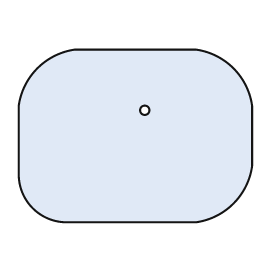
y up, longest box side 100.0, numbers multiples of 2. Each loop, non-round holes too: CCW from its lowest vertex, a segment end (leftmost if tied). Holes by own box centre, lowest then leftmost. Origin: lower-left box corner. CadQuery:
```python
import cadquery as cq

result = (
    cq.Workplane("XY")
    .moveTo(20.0, 0.0)
    .lineTo(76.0, 0.0)
    .threePointArc((92.0, 8.0), (100.0, 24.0))
    .lineTo(100.0, 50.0)
    .threePointArc((92.0, 66.0), (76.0, 74.0))
    .lineTo(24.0, 74.0)
    .threePointArc((8.0, 66.0), (0.0, 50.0))
    .lineTo(0.0, 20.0)
    .threePointArc((6.0, 6.0), (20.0, 0.0))
    .close()
    .moveTo(54.0, 48.0)
    .circle(2.0)
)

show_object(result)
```